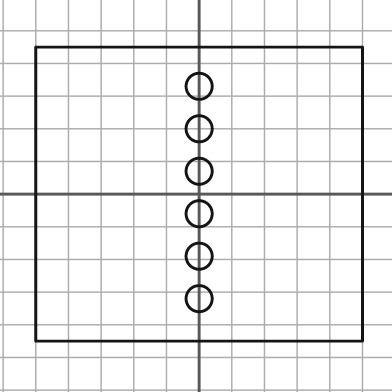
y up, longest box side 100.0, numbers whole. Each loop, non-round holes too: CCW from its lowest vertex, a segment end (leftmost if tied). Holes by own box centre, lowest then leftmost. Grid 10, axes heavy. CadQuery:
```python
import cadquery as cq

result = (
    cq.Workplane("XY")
    .moveTo(-50.0, -45.0)
    .lineTo(50.0, -45.0)
    .lineTo(50.0, 45.0)
    .lineTo(-50.0, 45.0)
    .close()
    .moveTo(0.0, -32.0)
    .circle(4.0)
    .moveTo(0.0, -19.0)
    .circle(4.0)
    .moveTo(0.0, -6.0)
    .circle(4.0)
    .moveTo(0.0, 7.0)
    .circle(4.0)
    .moveTo(0.0, 20.0)
    .circle(4.0)
    .moveTo(0.0, 33.0)
    .circle(4.0)
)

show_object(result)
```